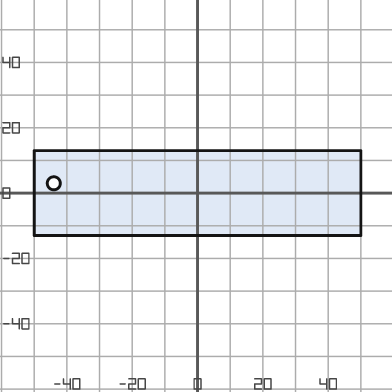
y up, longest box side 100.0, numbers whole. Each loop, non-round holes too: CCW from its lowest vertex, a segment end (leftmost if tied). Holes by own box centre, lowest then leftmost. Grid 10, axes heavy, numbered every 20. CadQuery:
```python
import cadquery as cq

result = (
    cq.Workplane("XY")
    .moveTo(-50.0, -13.0)
    .lineTo(50.0, -13.0)
    .lineTo(50.0, 13.0)
    .lineTo(-50.0, 13.0)
    .close()
    .moveTo(-44.0, 3.0)
    .circle(2.0)
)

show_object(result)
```